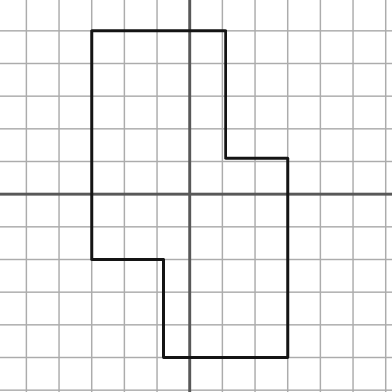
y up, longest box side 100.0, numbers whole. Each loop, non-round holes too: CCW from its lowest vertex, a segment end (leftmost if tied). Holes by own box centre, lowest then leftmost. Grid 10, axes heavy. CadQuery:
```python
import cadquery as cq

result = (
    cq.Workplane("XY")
    .moveTo(-8.0, -50.0)
    .lineTo(30.0, -50.0)
    .lineTo(30.0, 11.0)
    .lineTo(11.0, 11.0)
    .lineTo(11.0, 50.0)
    .lineTo(-30.0, 50.0)
    .lineTo(-30.0, -20.0)
    .lineTo(-8.0, -20.0)
    .close()
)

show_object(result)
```